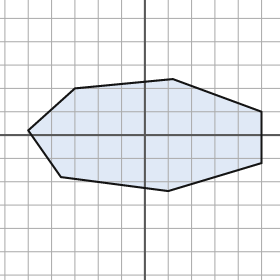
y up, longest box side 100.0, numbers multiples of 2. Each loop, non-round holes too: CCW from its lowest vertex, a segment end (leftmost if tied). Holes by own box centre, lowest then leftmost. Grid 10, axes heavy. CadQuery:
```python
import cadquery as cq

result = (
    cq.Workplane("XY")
    .moveTo(10.0, -24.0)
    .lineTo(50.0, -12.0)
    .lineTo(50.0, 10.0)
    .lineTo(12.0, 24.0)
    .lineTo(-30.0, 20.0)
    .lineTo(-50.0, 2.0)
    .lineTo(-36.0, -18.0)
    .close()
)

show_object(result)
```